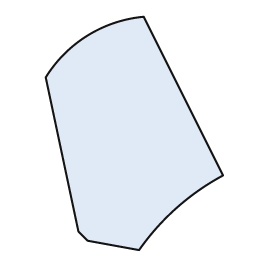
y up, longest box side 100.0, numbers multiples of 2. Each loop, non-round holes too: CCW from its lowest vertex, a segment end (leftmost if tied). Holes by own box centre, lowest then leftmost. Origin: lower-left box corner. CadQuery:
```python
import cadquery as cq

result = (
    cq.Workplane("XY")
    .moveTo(40.0, 0.0)
    .threePointArc((56.0, 18.0), (76.0, 32.0))
    .lineTo(42.0, 100.0)
    .threePointArc((18.0, 92.0), (0.0, 74.0))
    .lineTo(14.0, 8.0)
    .lineTo(18.0, 4.0)
    .close()
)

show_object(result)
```